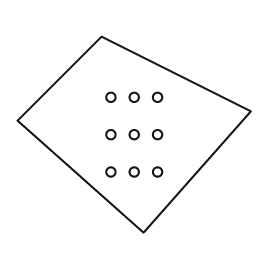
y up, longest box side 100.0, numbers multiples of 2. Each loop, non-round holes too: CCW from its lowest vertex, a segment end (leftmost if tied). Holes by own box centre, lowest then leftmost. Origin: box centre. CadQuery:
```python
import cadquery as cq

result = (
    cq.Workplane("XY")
    .moveTo(4.0, -42.0)
    .lineTo(50.0, 10.0)
    .lineTo(-14.0, 42.0)
    .lineTo(-50.0, 6.0)
    .close()
    .moveTo(-10.0, -16.0)
    .circle(2.0)
    .moveTo(0.0, -16.0)
    .circle(2.0)
    .moveTo(10.0, -16.0)
    .circle(2.0)
    .moveTo(-10.0, 0.0)
    .circle(2.0)
    .moveTo(0.0, 0.0)
    .circle(2.0)
    .moveTo(10.0, 0.0)
    .circle(2.0)
    .moveTo(-10.0, 16.0)
    .circle(2.0)
    .moveTo(0.0, 16.0)
    .circle(2.0)
    .moveTo(10.0, 16.0)
    .circle(2.0)
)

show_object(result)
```